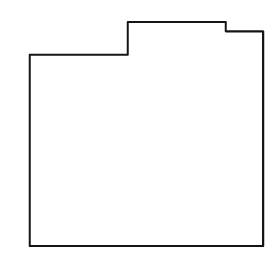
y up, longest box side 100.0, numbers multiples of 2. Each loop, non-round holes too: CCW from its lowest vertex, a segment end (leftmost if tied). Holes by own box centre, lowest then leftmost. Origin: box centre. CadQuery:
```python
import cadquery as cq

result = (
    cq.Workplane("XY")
    .moveTo(-50.0, -48.0)
    .lineTo(50.0, -48.0)
    .lineTo(50.0, 44.0)
    .lineTo(34.0, 44.0)
    .lineTo(34.0, 48.0)
    .lineTo(-8.0, 48.0)
    .lineTo(-8.0, 34.0)
    .lineTo(-50.0, 34.0)
    .close()
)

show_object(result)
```